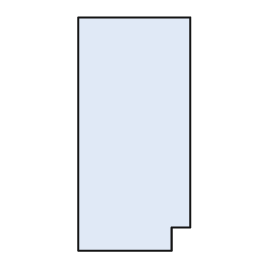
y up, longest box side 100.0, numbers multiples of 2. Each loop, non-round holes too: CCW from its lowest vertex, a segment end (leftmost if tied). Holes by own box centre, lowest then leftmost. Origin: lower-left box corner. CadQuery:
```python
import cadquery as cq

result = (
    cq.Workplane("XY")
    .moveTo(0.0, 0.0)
    .lineTo(40.0, 0.0)
    .lineTo(40.0, 10.0)
    .lineTo(48.0, 10.0)
    .lineTo(48.0, 100.0)
    .lineTo(0.0, 100.0)
    .close()
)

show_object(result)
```